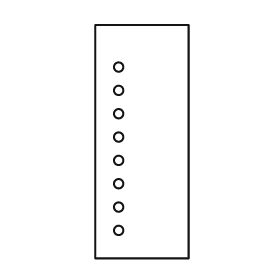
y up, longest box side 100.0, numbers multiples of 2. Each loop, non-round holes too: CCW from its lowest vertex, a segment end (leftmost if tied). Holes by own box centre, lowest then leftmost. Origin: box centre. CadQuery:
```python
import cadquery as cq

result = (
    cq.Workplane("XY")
    .moveTo(-20.0, -50.0)
    .lineTo(20.0, -50.0)
    .lineTo(20.0, 50.0)
    .lineTo(-20.0, 50.0)
    .close()
    .moveTo(-10.0, -38.0)
    .circle(2.0)
    .moveTo(-10.0, -28.0)
    .circle(2.0)
    .moveTo(-10.0, -18.0)
    .circle(2.0)
    .moveTo(-10.0, -8.0)
    .circle(2.0)
    .moveTo(-10.0, 2.0)
    .circle(2.0)
    .moveTo(-10.0, 12.0)
    .circle(2.0)
    .moveTo(-10.0, 22.0)
    .circle(2.0)
    .moveTo(-10.0, 32.0)
    .circle(2.0)
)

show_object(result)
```